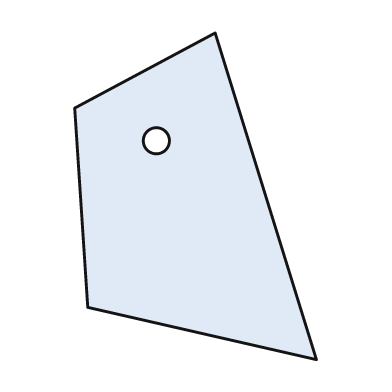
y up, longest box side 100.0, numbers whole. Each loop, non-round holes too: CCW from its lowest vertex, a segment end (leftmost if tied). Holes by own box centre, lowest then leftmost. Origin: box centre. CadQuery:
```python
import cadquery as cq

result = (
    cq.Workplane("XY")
    .moveTo(37.0, -50.0)
    .lineTo(6.0, 50.0)
    .lineTo(-37.0, 27.0)
    .lineTo(-33.0, -34.0)
    .close()
    .moveTo(-12.0, 17.0)
    .circle(4.0)
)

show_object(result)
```